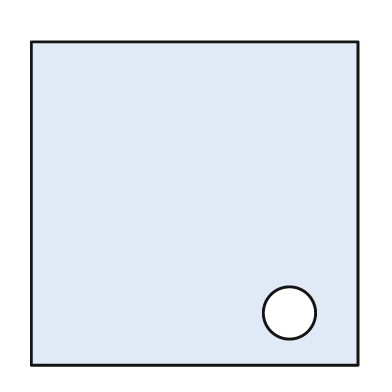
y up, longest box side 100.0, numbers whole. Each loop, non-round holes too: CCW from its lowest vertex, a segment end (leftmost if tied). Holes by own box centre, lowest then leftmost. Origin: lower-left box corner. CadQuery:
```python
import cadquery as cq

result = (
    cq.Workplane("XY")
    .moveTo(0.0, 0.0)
    .lineTo(100.0, 0.0)
    .lineTo(100.0, 99.0)
    .lineTo(0.0, 99.0)
    .close()
    .moveTo(79.0, 16.0)
    .circle(8.0)
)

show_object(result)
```